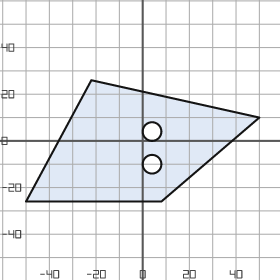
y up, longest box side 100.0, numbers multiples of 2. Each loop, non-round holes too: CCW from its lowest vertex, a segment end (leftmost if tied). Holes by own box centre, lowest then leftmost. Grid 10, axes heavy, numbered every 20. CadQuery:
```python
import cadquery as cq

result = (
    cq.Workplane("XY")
    .moveTo(-50.0, -26.0)
    .lineTo(8.0, -26.0)
    .lineTo(50.0, 10.0)
    .lineTo(-22.0, 26.0)
    .close()
    .moveTo(4.0, -10.0)
    .circle(4.0)
    .moveTo(4.0, 4.0)
    .circle(4.0)
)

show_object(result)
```